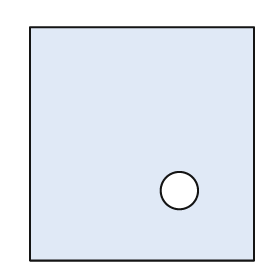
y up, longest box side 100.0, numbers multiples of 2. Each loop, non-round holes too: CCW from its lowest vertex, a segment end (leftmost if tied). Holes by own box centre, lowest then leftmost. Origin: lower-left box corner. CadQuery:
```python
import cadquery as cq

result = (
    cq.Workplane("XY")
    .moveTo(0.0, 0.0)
    .lineTo(96.0, 0.0)
    .lineTo(96.0, 100.0)
    .lineTo(0.0, 100.0)
    .close()
    .moveTo(64.0, 30.0)
    .circle(8.0)
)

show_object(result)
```